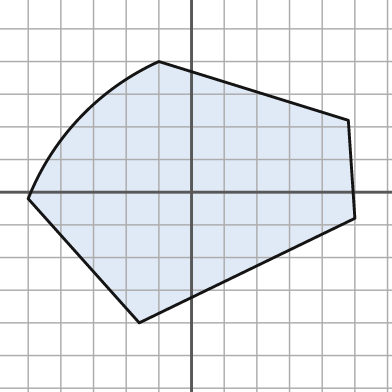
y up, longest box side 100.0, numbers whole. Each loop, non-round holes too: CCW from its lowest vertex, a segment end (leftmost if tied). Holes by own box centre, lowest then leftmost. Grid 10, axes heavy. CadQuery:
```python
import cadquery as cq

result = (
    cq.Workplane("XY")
    .moveTo(-16.0, -40.0)
    .lineTo(50.0, -8.0)
    .lineTo(48.0, 22.0)
    .lineTo(-10.0, 40.0)
    .threePointArc((-34.0, 23.0), (-50.0, -2.0))
    .close()
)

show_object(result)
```